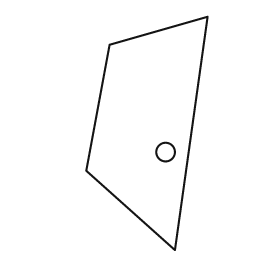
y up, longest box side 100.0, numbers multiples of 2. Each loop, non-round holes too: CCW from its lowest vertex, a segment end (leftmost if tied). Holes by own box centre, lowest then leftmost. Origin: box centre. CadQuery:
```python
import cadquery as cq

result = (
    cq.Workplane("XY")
    .moveTo(12.0, -50.0)
    .lineTo(26.0, 50.0)
    .lineTo(-16.0, 38.0)
    .lineTo(-26.0, -16.0)
    .close()
    .moveTo(8.0, -8.0)
    .circle(4.0)
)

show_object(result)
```